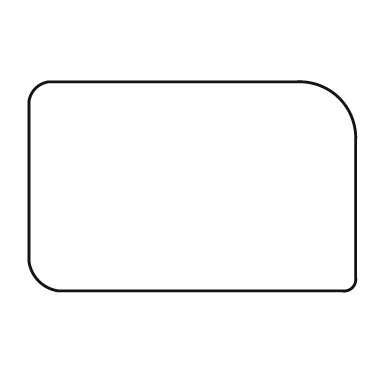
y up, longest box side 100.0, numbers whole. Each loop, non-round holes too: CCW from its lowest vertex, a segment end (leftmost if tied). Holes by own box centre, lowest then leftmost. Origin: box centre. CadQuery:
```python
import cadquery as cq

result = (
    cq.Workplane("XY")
    .moveTo(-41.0, -32.0)
    .lineTo(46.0, -32.0)
    .threePointArc((49.0, -31.0), (50.0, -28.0))
    .lineTo(50.0, 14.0)
    .threePointArc((45.0, 27.0), (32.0, 32.0))
    .lineTo(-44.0, 32.0)
    .threePointArc((-48.0, 30.0), (-50.0, 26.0))
    .lineTo(-50.0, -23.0)
    .threePointArc((-47.0, -29.0), (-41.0, -32.0))
    .close()
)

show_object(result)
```